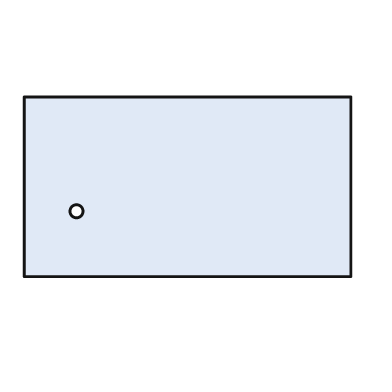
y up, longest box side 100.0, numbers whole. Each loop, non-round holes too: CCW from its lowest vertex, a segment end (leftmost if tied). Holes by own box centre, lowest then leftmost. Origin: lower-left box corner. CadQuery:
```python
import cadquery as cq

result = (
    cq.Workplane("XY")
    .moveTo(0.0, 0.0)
    .lineTo(100.0, 0.0)
    .lineTo(100.0, 55.0)
    .lineTo(0.0, 55.0)
    .close()
    .moveTo(16.0, 20.0)
    .circle(2.0)
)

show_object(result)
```